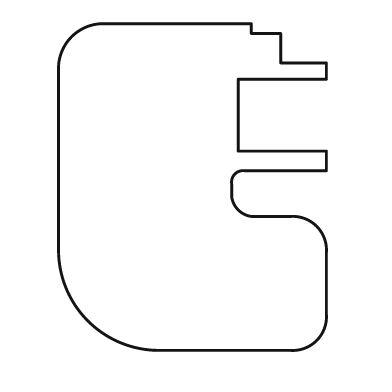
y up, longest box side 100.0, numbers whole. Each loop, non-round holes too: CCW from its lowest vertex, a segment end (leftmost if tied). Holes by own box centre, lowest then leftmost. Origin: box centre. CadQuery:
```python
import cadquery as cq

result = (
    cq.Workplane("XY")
    .moveTo(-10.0, -50.0)
    .lineTo(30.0, -50.0)
    .threePointArc((38.0, -47.0), (41.0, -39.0))
    .lineTo(41.0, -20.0)
    .threePointArc((38.0, -12.0), (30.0, -9.0))
    .lineTo(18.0, -9.0)
    .threePointArc((14.0, -7.0), (12.0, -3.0))
    .lineTo(12.0, 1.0)
    .threePointArc((13.0, 4.0), (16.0, 5.0))
    .lineTo(41.0, 5.0)
    .lineTo(41.0, 11.0)
    .lineTo(14.0, 11.0)
    .lineTo(14.0, 33.0)
    .lineTo(41.0, 33.0)
    .lineTo(41.0, 38.0)
    .lineTo(27.0, 38.0)
    .lineTo(27.0, 47.0)
    .lineTo(18.0, 47.0)
    .lineTo(18.0, 50.0)
    .lineTo(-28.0, 50.0)
    .threePointArc((-37.0, 46.0), (-41.0, 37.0))
    .lineTo(-41.0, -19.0)
    .threePointArc((-32.0, -41.0), (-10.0, -50.0))
    .close()
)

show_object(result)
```